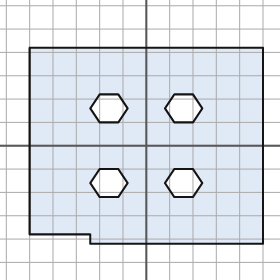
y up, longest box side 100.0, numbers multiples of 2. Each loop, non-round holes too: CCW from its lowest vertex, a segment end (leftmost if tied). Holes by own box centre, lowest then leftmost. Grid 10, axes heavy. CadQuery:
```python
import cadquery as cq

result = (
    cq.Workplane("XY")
    .moveTo(-24.0, -42.0)
    .lineTo(50.0, -42.0)
    .lineTo(50.0, 42.0)
    .lineTo(-50.0, 42.0)
    .lineTo(-50.0, -38.0)
    .lineTo(-24.0, -38.0)
    .close()
    .moveTo(-20.0, -22.0)
    .lineTo(-12.0, -22.0)
    .lineTo(-8.0, -16.0)
    .lineTo(-12.0, -10.0)
    .lineTo(-20.0, -10.0)
    .lineTo(-24.0, -16.0)
    .close()
    .moveTo(12.0, -22.0)
    .lineTo(20.0, -22.0)
    .lineTo(24.0, -16.0)
    .lineTo(20.0, -10.0)
    .lineTo(12.0, -10.0)
    .lineTo(8.0, -16.0)
    .close()
    .moveTo(-20.0, 10.0)
    .lineTo(-12.0, 10.0)
    .lineTo(-8.0, 16.0)
    .lineTo(-12.0, 22.0)
    .lineTo(-20.0, 22.0)
    .lineTo(-24.0, 16.0)
    .close()
    .moveTo(12.0, 10.0)
    .lineTo(20.0, 10.0)
    .lineTo(24.0, 16.0)
    .lineTo(20.0, 22.0)
    .lineTo(12.0, 22.0)
    .lineTo(8.0, 16.0)
    .close()
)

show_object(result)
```